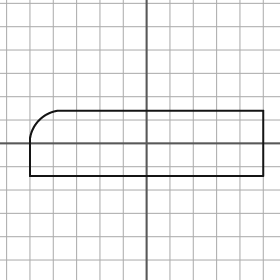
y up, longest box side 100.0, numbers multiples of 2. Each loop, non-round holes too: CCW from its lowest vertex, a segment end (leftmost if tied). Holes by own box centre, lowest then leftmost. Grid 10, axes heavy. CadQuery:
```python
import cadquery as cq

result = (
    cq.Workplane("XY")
    .moveTo(-50.0, -14.0)
    .lineTo(50.0, -14.0)
    .lineTo(50.0, 14.0)
    .lineTo(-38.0, 14.0)
    .threePointArc((-46.0, 10.0), (-50.0, 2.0))
    .close()
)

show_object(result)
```